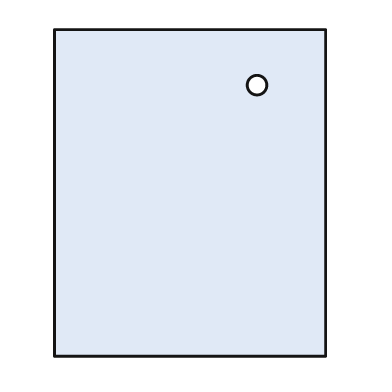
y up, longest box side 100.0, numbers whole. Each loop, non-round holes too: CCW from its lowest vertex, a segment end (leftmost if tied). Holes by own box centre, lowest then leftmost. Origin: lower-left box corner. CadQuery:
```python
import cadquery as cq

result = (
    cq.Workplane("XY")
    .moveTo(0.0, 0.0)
    .lineTo(83.0, 0.0)
    .lineTo(83.0, 100.0)
    .lineTo(0.0, 100.0)
    .close()
    .moveTo(62.0, 83.0)
    .circle(3.0)
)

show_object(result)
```